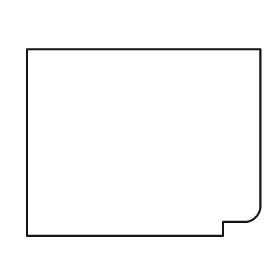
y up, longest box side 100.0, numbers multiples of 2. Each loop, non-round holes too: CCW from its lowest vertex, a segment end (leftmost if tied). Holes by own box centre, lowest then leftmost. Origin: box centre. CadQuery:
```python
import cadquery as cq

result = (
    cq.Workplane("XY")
    .moveTo(-50.0, -40.0)
    .lineTo(34.0, -40.0)
    .lineTo(34.0, -34.0)
    .lineTo(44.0, -34.0)
    .threePointArc((48.0, -32.0), (50.0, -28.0))
    .lineTo(50.0, 40.0)
    .lineTo(-50.0, 40.0)
    .close()
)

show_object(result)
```